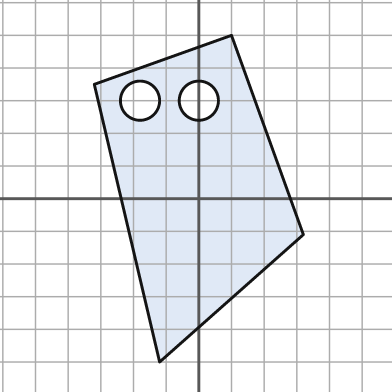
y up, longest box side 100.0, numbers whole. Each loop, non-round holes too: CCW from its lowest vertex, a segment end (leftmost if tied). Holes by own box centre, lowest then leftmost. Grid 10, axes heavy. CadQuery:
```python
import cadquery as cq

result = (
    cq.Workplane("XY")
    .moveTo(-12.0, -50.0)
    .lineTo(32.0, -11.0)
    .lineTo(10.0, 50.0)
    .lineTo(-32.0, 35.0)
    .close()
    .moveTo(-18.0, 30.0)
    .circle(6.0)
    .moveTo(0.0, 30.0)
    .circle(6.0)
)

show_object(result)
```